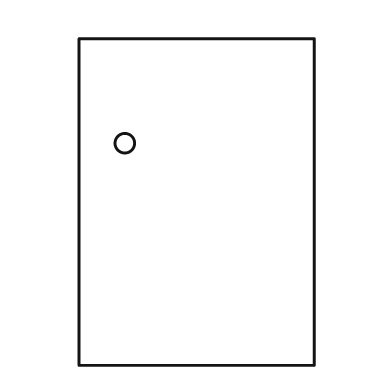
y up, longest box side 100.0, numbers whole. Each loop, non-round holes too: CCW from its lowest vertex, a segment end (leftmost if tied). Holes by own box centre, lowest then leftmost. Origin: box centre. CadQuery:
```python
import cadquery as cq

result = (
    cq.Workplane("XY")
    .moveTo(-36.0, -50.0)
    .lineTo(36.0, -50.0)
    .lineTo(36.0, 50.0)
    .lineTo(-36.0, 50.0)
    .close()
    .moveTo(-22.0, 18.0)
    .circle(3.0)
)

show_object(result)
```